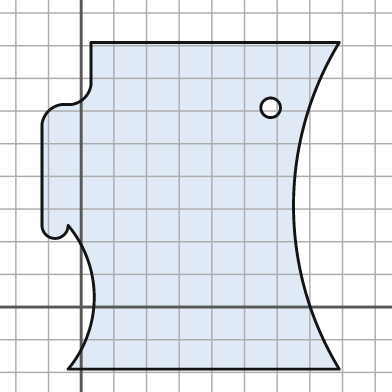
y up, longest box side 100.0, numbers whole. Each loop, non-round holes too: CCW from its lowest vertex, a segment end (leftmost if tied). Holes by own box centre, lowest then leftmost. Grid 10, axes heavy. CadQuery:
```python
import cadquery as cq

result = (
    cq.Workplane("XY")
    .moveTo(-4.0, -19.0)
    .lineTo(79.0, -19.0)
    .threePointArc((65.0, 31.0), (79.0, 81.0))
    .lineTo(3.0, 81.0)
    .lineTo(3.0, 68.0)
    .threePointArc((1.0, 64.0), (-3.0, 62.0))
    .lineTo(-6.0, 62.0)
    .threePointArc((-10.0, 60.0), (-12.0, 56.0))
    .lineTo(-12.0, 25.0)
    .threePointArc((-8.0, 21.0), (-4.0, 25.0))
    .threePointArc((4.0, 3.0), (-4.0, -19.0))
    .close()
    .moveTo(58.0, 61.0)
    .circle(3.0)
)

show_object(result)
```